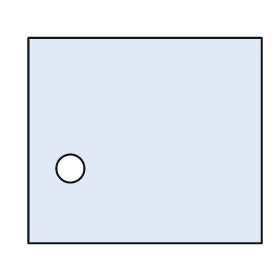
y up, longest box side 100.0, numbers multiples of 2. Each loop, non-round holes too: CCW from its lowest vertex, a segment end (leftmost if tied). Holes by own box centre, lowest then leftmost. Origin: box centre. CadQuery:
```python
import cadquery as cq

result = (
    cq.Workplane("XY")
    .moveTo(-50.0, -44.0)
    .lineTo(50.0, -44.0)
    .lineTo(50.0, 44.0)
    .lineTo(-50.0, 44.0)
    .close()
    .moveTo(-32.0, -12.0)
    .circle(6.0)
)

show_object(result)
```